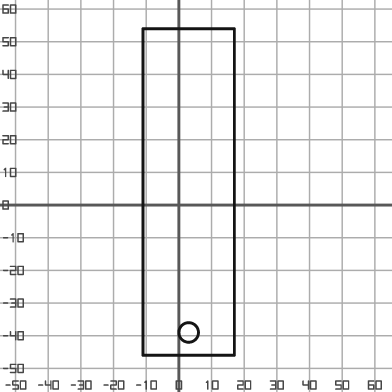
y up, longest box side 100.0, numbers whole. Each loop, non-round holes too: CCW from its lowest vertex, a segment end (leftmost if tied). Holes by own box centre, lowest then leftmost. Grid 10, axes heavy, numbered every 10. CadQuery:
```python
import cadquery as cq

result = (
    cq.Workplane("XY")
    .moveTo(-11.0, -46.0)
    .lineTo(17.0, -46.0)
    .lineTo(17.0, 54.0)
    .lineTo(-11.0, 54.0)
    .close()
    .moveTo(3.0, -39.0)
    .circle(3.0)
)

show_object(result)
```